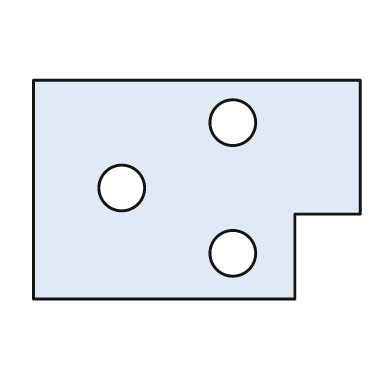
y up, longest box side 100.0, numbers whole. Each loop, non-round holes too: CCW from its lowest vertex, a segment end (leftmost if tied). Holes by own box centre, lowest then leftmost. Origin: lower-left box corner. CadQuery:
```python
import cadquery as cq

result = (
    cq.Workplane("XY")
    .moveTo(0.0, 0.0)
    .lineTo(80.0, 0.0)
    .lineTo(80.0, 26.0)
    .lineTo(100.0, 26.0)
    .lineTo(100.0, 67.0)
    .lineTo(0.0, 67.0)
    .close()
    .moveTo(61.0, 14.0)
    .circle(7.0)
    .moveTo(27.0, 34.0)
    .circle(7.0)
    .moveTo(61.0, 54.0)
    .circle(7.0)
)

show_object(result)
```